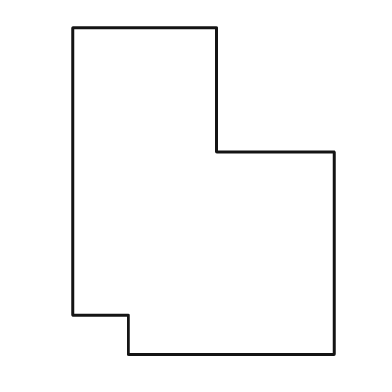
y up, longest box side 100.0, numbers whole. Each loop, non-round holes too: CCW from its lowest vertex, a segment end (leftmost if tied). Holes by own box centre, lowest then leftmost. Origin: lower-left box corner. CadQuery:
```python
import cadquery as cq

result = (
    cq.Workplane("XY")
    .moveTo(17.0, 0.0)
    .lineTo(80.0, 0.0)
    .lineTo(80.0, 62.0)
    .lineTo(44.0, 62.0)
    .lineTo(44.0, 100.0)
    .lineTo(0.0, 100.0)
    .lineTo(0.0, 12.0)
    .lineTo(17.0, 12.0)
    .close()
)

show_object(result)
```